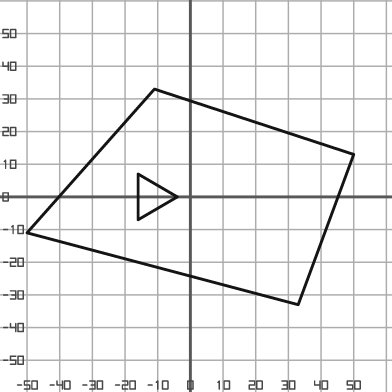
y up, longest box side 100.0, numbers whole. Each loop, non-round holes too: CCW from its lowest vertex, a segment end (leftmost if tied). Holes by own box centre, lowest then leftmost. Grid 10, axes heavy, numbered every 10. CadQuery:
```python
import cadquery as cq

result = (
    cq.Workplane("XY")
    .moveTo(33.0, -33.0)
    .lineTo(50.0, 13.0)
    .lineTo(-11.0, 33.0)
    .lineTo(-50.0, -11.0)
    .close()
    .moveTo(-16.0, -7.0)
    .lineTo(-4.0, 0.0)
    .lineTo(-16.0, 7.0)
    .close()
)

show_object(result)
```